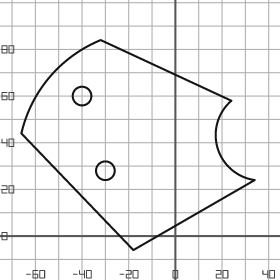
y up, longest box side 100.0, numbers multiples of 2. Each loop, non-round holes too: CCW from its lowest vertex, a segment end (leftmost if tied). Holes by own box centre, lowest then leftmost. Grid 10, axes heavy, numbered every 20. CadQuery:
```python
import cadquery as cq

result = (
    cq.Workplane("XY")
    .moveTo(-18.0, -6.0)
    .lineTo(34.0, 24.0)
    .threePointArc((18.0, 38.0), (24.0, 58.0))
    .lineTo(-32.0, 84.0)
    .threePointArc((-54.0, 68.0), (-66.0, 44.0))
    .close()
    .moveTo(-30.0, 28.0)
    .circle(4.0)
    .moveTo(-40.0, 60.0)
    .circle(4.0)
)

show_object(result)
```